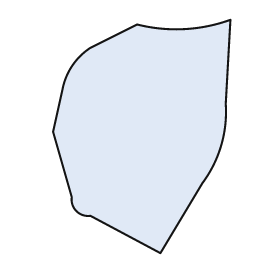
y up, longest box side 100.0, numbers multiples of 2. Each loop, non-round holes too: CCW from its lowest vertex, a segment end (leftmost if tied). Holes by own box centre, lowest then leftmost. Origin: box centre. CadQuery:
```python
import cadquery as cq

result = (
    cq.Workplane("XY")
    .moveTo(8.0, -50.0)
    .lineTo(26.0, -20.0)
    .threePointArc((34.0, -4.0), (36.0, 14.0))
    .lineTo(38.0, 50.0)
    .threePointArc((18.0, 46.0), (-2.0, 48.0))
    .lineTo(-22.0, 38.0)
    .threePointArc((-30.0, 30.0), (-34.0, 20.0))
    .lineTo(-38.0, 2.0)
    .lineTo(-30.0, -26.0)
    .threePointArc((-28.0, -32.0), (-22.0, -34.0))
    .close()
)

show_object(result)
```